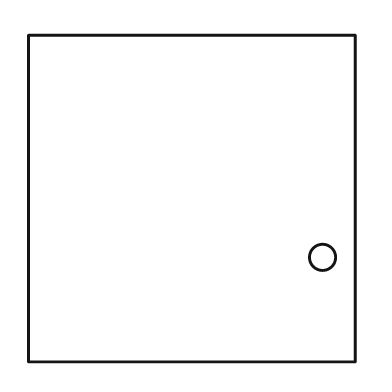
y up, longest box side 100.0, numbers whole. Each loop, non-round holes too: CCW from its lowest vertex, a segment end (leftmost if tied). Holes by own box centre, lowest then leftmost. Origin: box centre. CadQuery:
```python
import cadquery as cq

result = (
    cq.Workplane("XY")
    .moveTo(-50.0, -50.0)
    .lineTo(50.0, -50.0)
    .lineTo(50.0, 50.0)
    .lineTo(-50.0, 50.0)
    .close()
    .moveTo(40.0, -18.0)
    .circle(4.0)
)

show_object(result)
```